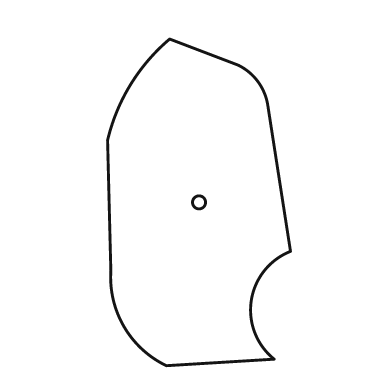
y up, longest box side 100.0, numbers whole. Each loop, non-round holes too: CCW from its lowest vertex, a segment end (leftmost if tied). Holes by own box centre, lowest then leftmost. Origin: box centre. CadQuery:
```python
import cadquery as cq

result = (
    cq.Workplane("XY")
    .moveTo(-10.0, -50.0)
    .lineTo(23.0, -48.0)
    .threePointArc((16.0, -30.0), (28.0, -15.0))
    .lineTo(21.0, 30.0)
    .threePointArc((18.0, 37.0), (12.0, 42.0))
    .lineTo(-9.0, 50.0)
    .threePointArc((-21.0, 36.0), (-28.0, 19.0))
    .lineTo(-27.0, -21.0)
    .threePointArc((-23.0, -38.0), (-10.0, -50.0))
    .close()
    .moveTo(0.0, 0.0)
    .circle(2.0)
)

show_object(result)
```